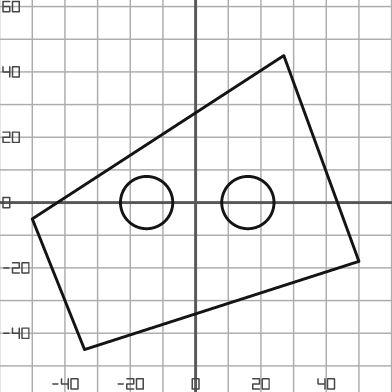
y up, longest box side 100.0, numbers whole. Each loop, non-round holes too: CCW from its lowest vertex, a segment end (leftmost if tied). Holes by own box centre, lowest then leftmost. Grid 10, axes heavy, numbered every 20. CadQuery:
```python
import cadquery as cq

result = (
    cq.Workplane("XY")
    .moveTo(-34.0, -45.0)
    .lineTo(50.0, -18.0)
    .lineTo(27.0, 45.0)
    .lineTo(-50.0, -5.0)
    .close()
    .moveTo(-15.0, 0.0)
    .circle(8.0)
    .moveTo(16.0, 0.0)
    .circle(8.0)
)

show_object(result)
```